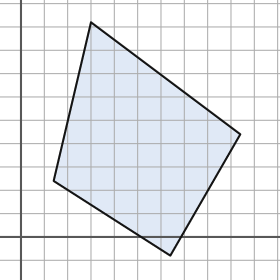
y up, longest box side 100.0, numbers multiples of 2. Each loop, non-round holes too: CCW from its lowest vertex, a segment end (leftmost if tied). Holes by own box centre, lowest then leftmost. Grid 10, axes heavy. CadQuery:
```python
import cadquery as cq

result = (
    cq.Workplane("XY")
    .moveTo(64.0, -8.0)
    .lineTo(94.0, 44.0)
    .lineTo(30.0, 92.0)
    .lineTo(14.0, 24.0)
    .close()
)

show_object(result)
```